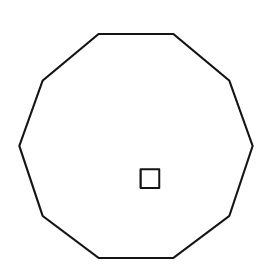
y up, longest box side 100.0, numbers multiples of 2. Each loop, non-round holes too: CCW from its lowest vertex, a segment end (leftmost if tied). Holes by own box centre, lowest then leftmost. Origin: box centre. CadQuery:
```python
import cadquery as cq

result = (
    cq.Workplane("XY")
    .moveTo(-16.0, -48.0)
    .lineTo(16.0, -48.0)
    .lineTo(40.0, -30.0)
    .lineTo(50.0, 0.0)
    .lineTo(40.0, 28.0)
    .lineTo(16.0, 48.0)
    .lineTo(-16.0, 48.0)
    .lineTo(-40.0, 28.0)
    .lineTo(-50.0, 0.0)
    .lineTo(-40.0, -30.0)
    .close()
    .moveTo(2.0, -18.0)
    .lineTo(10.0, -18.0)
    .lineTo(10.0, -10.0)
    .lineTo(2.0, -10.0)
    .close()
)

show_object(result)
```